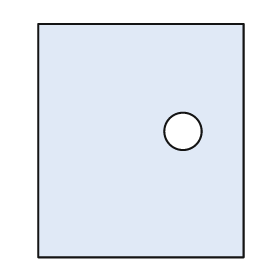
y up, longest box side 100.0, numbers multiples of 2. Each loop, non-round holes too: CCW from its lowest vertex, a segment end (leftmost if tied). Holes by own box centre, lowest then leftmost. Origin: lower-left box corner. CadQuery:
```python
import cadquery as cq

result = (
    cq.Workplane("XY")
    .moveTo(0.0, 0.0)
    .lineTo(88.0, 0.0)
    .lineTo(88.0, 100.0)
    .lineTo(0.0, 100.0)
    .close()
    .moveTo(62.0, 54.0)
    .circle(8.0)
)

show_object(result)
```